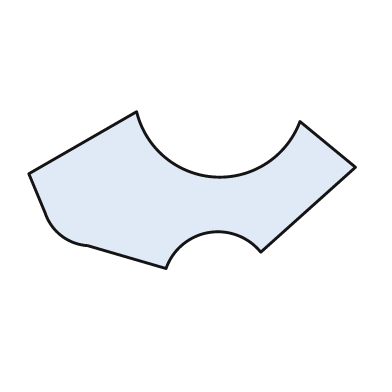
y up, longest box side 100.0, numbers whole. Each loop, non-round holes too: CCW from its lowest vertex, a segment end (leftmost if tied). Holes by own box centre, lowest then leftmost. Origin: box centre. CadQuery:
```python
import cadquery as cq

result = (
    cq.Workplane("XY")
    .moveTo(-8.0, -24.0)
    .threePointArc((5.0, -13.0), (21.0, -19.0))
    .lineTo(50.0, 7.0)
    .lineTo(33.0, 21.0)
    .threePointArc((7.0, 4.0), (-17.0, 24.0))
    .lineTo(-50.0, 5.0)
    .lineTo(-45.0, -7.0)
    .threePointArc((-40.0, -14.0), (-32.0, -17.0))
    .close()
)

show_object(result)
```